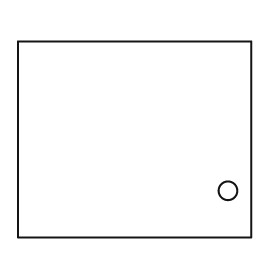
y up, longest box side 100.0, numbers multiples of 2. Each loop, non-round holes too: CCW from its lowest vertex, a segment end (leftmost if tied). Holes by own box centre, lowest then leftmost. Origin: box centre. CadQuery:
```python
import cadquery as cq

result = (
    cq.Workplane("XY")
    .moveTo(-50.0, -42.0)
    .lineTo(50.0, -42.0)
    .lineTo(50.0, 42.0)
    .lineTo(-50.0, 42.0)
    .close()
    .moveTo(40.0, -22.0)
    .circle(4.0)
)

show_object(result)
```